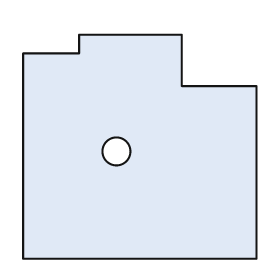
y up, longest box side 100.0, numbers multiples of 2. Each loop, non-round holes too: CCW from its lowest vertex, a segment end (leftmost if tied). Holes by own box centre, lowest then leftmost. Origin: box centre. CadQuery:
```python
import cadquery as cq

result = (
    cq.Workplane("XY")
    .moveTo(-50.0, -48.0)
    .lineTo(50.0, -48.0)
    .lineTo(50.0, 26.0)
    .lineTo(18.0, 26.0)
    .lineTo(18.0, 48.0)
    .lineTo(-26.0, 48.0)
    .lineTo(-26.0, 40.0)
    .lineTo(-50.0, 40.0)
    .close()
    .moveTo(-10.0, -2.0)
    .circle(6.0)
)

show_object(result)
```